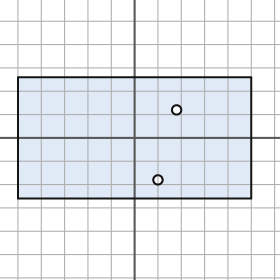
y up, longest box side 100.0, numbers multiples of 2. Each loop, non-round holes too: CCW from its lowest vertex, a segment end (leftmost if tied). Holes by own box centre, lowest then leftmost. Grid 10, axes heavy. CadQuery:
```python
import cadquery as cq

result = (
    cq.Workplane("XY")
    .moveTo(-50.0, -26.0)
    .lineTo(50.0, -26.0)
    .lineTo(50.0, 26.0)
    .lineTo(-50.0, 26.0)
    .close()
    .moveTo(10.0, -18.0)
    .circle(2.0)
    .moveTo(18.0, 12.0)
    .circle(2.0)
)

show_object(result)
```